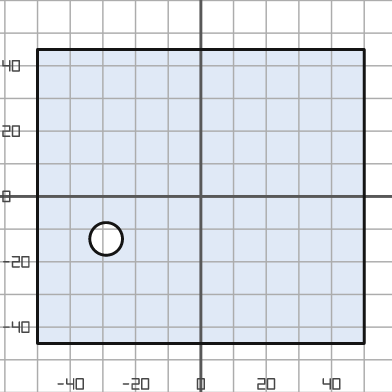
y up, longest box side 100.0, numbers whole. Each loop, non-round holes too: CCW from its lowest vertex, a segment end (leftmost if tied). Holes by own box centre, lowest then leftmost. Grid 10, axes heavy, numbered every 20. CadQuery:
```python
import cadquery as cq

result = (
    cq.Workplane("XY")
    .moveTo(-50.0, -45.0)
    .lineTo(50.0, -45.0)
    .lineTo(50.0, 45.0)
    .lineTo(-50.0, 45.0)
    .close()
    .moveTo(-29.0, -13.0)
    .circle(5.0)
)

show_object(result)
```